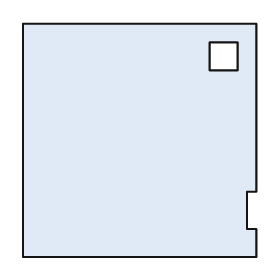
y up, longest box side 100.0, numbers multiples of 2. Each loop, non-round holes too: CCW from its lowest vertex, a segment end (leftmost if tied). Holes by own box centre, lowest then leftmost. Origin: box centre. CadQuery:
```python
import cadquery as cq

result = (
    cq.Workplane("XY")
    .moveTo(-50.0, -50.0)
    .lineTo(50.0, -50.0)
    .lineTo(50.0, -38.0)
    .lineTo(46.0, -38.0)
    .lineTo(46.0, -22.0)
    .lineTo(50.0, -22.0)
    .lineTo(50.0, 50.0)
    .lineTo(-50.0, 50.0)
    .close()
    .moveTo(30.0, 30.0)
    .lineTo(42.0, 30.0)
    .lineTo(42.0, 42.0)
    .lineTo(30.0, 42.0)
    .close()
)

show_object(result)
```